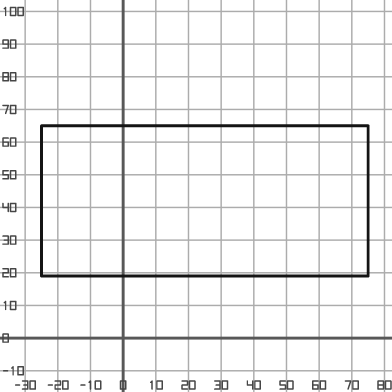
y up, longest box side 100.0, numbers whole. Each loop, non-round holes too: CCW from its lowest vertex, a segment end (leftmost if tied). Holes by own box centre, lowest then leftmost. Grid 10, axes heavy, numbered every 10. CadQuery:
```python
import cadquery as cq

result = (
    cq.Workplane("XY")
    .moveTo(-25.0, 19.0)
    .lineTo(75.0, 19.0)
    .lineTo(75.0, 65.0)
    .lineTo(-25.0, 65.0)
    .close()
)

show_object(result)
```